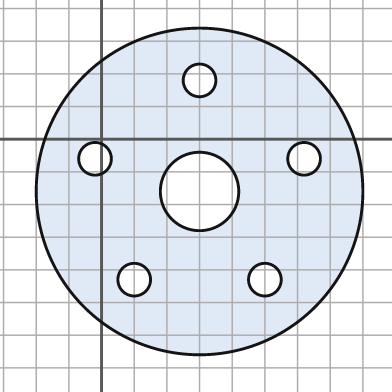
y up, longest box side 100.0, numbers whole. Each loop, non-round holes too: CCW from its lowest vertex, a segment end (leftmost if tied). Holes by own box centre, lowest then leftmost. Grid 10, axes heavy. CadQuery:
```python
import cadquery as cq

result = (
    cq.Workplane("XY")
    .moveTo(30.0, -16.0)
    .circle(50.0)
    .moveTo(10.0, -43.0)
    .circle(5.0)
    .moveTo(50.0, -43.0)
    .circle(5.0)
    .moveTo(30.0, -16.0)
    .circle(12.0)
    .moveTo(-2.0, -6.0)
    .circle(5.0)
    .moveTo(62.0, -6.0)
    .circle(5.0)
    .moveTo(30.0, 18.0)
    .circle(5.0)
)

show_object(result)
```